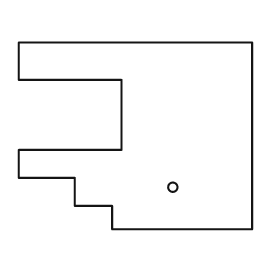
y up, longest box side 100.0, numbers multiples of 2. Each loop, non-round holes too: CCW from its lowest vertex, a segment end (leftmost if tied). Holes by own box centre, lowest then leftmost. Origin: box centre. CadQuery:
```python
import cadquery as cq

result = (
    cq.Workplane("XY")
    .moveTo(-10.0, -40.0)
    .lineTo(50.0, -40.0)
    .lineTo(50.0, 40.0)
    .lineTo(-50.0, 40.0)
    .lineTo(-50.0, 24.0)
    .lineTo(-6.0, 24.0)
    .lineTo(-6.0, -6.0)
    .lineTo(-50.0, -6.0)
    .lineTo(-50.0, -18.0)
    .lineTo(-26.0, -18.0)
    .lineTo(-26.0, -30.0)
    .lineTo(-10.0, -30.0)
    .close()
    .moveTo(16.0, -22.0)
    .circle(2.0)
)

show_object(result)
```